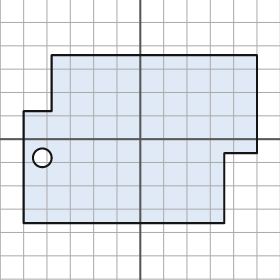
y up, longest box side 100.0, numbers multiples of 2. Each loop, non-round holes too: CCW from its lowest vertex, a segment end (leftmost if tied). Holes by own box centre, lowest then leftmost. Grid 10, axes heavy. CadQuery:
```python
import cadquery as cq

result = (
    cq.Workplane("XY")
    .moveTo(-50.0, -36.0)
    .lineTo(36.0, -36.0)
    .lineTo(36.0, -6.0)
    .lineTo(50.0, -6.0)
    .lineTo(50.0, 36.0)
    .lineTo(-38.0, 36.0)
    .lineTo(-38.0, 12.0)
    .lineTo(-50.0, 12.0)
    .close()
    .moveTo(-42.0, -8.0)
    .circle(4.0)
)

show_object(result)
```